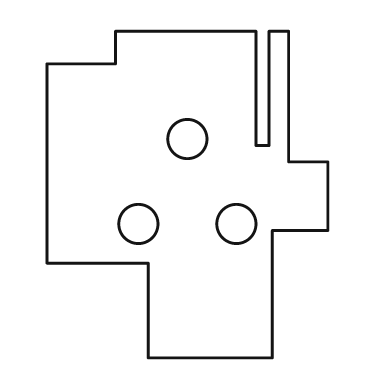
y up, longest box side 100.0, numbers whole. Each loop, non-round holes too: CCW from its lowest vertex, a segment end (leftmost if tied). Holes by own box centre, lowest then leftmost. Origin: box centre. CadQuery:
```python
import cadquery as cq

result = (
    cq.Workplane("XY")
    .moveTo(-12.0, -50.0)
    .lineTo(26.0, -50.0)
    .lineTo(26.0, -11.0)
    .lineTo(43.0, -11.0)
    .lineTo(43.0, 10.0)
    .lineTo(31.0, 10.0)
    .lineTo(31.0, 50.0)
    .lineTo(25.0, 50.0)
    .lineTo(25.0, 15.0)
    .lineTo(21.0, 15.0)
    .lineTo(21.0, 50.0)
    .lineTo(-22.0, 50.0)
    .lineTo(-22.0, 40.0)
    .lineTo(-43.0, 40.0)
    .lineTo(-43.0, -21.0)
    .lineTo(-12.0, -21.0)
    .close()
    .moveTo(-15.0, -9.0)
    .circle(6.0)
    .moveTo(15.0, -9.0)
    .circle(6.0)
    .moveTo(0.0, 17.0)
    .circle(6.0)
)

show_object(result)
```